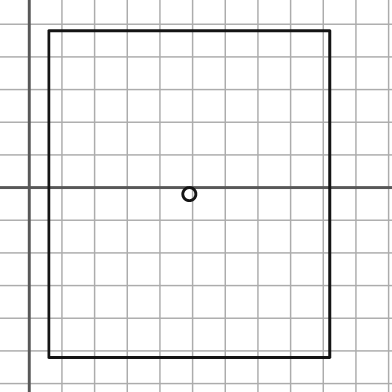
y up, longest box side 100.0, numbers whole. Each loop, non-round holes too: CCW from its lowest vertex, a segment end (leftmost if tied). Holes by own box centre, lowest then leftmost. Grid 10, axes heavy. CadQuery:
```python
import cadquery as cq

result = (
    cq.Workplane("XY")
    .moveTo(6.0, -52.0)
    .lineTo(92.0, -52.0)
    .lineTo(92.0, 48.0)
    .lineTo(6.0, 48.0)
    .close()
    .moveTo(49.0, -2.0)
    .circle(2.0)
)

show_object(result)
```